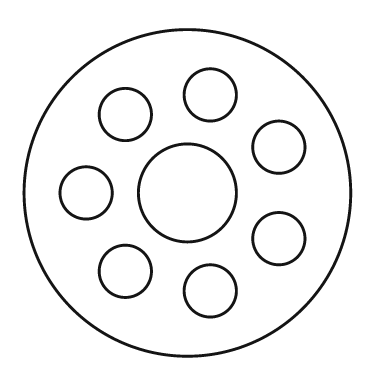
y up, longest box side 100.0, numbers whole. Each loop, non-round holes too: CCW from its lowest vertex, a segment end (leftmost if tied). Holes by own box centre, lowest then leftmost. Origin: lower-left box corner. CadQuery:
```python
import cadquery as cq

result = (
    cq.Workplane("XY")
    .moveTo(50.0, 50.0)
    .circle(50.0)
    .moveTo(57.0, 20.0)
    .circle(8.0)
    .moveTo(31.0, 26.0)
    .circle(8.0)
    .moveTo(78.0, 36.0)
    .circle(8.0)
    .moveTo(19.0, 50.0)
    .circle(8.0)
    .moveTo(50.0, 50.0)
    .circle(15.0)
    .moveTo(78.0, 64.0)
    .circle(8.0)
    .moveTo(31.0, 74.0)
    .circle(8.0)
    .moveTo(57.0, 80.0)
    .circle(8.0)
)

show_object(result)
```